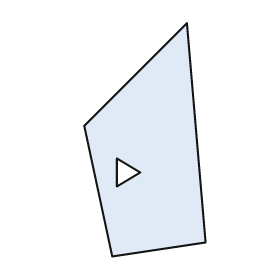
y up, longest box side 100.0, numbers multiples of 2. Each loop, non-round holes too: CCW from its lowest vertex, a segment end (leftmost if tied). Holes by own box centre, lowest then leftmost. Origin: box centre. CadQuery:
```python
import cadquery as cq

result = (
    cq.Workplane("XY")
    .moveTo(-14.0, -50.0)
    .lineTo(26.0, -44.0)
    .lineTo(18.0, 50.0)
    .lineTo(-26.0, 6.0)
    .close()
    .moveTo(-12.0, -20.0)
    .lineTo(-2.0, -14.0)
    .lineTo(-12.0, -8.0)
    .close()
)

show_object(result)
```